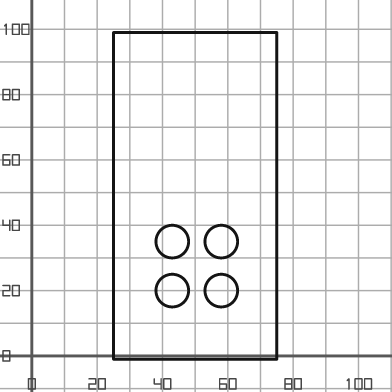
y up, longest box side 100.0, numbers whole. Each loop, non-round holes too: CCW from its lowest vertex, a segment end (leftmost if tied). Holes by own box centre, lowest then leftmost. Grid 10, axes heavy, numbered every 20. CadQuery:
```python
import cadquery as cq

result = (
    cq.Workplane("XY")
    .moveTo(25.0, -1.0)
    .lineTo(75.0, -1.0)
    .lineTo(75.0, 99.0)
    .lineTo(25.0, 99.0)
    .close()
    .moveTo(43.0, 20.0)
    .circle(5.0)
    .moveTo(58.0, 20.0)
    .circle(5.0)
    .moveTo(43.0, 35.0)
    .circle(5.0)
    .moveTo(58.0, 35.0)
    .circle(5.0)
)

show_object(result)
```